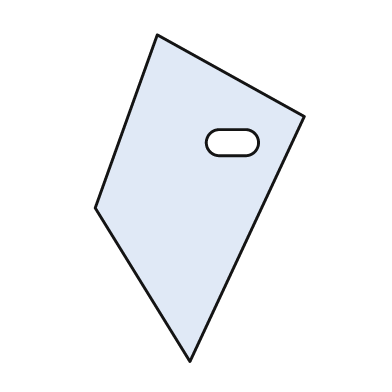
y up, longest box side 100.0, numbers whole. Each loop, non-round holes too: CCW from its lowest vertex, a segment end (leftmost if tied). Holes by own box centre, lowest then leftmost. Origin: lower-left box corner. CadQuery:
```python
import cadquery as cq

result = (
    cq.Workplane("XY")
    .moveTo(29.0, 0.0)
    .lineTo(64.0, 75.0)
    .lineTo(19.0, 100.0)
    .lineTo(0.0, 47.0)
    .close()
    .moveTo(38.0, 63.0)
    .lineTo(46.0, 63.0)
    .threePointArc((50.0, 67.0), (46.0, 71.0))
    .lineTo(38.0, 71.0)
    .threePointArc((34.0, 67.0), (38.0, 63.0))
    .close()
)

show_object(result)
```